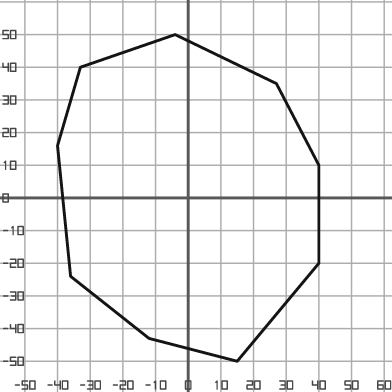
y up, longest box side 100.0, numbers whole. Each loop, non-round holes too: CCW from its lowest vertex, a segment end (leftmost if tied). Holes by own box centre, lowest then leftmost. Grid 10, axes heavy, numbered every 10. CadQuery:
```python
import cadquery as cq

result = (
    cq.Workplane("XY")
    .moveTo(15.0, -50.0)
    .lineTo(40.0, -20.0)
    .lineTo(40.0, 10.0)
    .lineTo(27.0, 35.0)
    .lineTo(-4.0, 50.0)
    .lineTo(-33.0, 40.0)
    .lineTo(-40.0, 16.0)
    .lineTo(-36.0, -24.0)
    .lineTo(-12.0, -43.0)
    .close()
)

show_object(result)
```